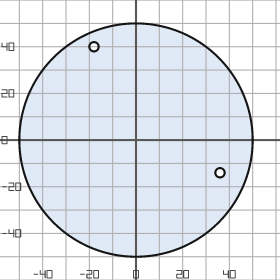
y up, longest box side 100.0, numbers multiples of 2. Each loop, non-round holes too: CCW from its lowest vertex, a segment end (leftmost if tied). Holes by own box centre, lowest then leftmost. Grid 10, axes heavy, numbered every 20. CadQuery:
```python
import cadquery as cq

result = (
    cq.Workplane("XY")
    .moveTo(0.0, 0.0)
    .circle(50.0)
    .moveTo(36.0, -14.0)
    .circle(2.0)
    .moveTo(-18.0, 40.0)
    .circle(2.0)
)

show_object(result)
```